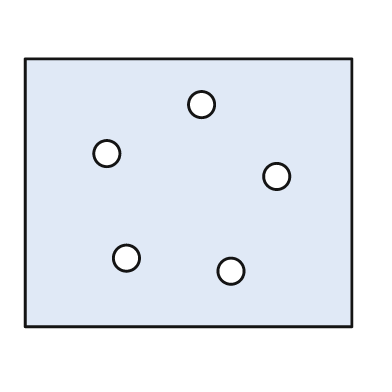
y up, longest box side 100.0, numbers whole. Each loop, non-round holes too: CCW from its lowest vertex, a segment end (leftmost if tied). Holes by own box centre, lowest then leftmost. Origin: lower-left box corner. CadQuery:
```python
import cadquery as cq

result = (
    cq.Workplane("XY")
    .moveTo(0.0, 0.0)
    .lineTo(100.0, 0.0)
    .lineTo(100.0, 82.0)
    .lineTo(0.0, 82.0)
    .close()
    .moveTo(63.0, 17.0)
    .circle(4.0)
    .moveTo(31.0, 21.0)
    .circle(4.0)
    .moveTo(77.0, 46.0)
    .circle(4.0)
    .moveTo(25.0, 53.0)
    .circle(4.0)
    .moveTo(54.0, 68.0)
    .circle(4.0)
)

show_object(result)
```